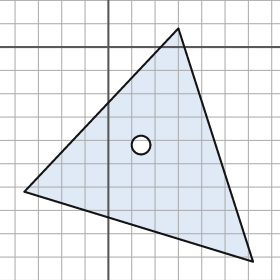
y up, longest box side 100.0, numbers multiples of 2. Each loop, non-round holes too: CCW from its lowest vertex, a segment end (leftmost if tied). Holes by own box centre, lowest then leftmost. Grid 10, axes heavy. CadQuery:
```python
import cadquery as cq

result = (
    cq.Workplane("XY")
    .moveTo(62.0, -92.0)
    .lineTo(30.0, 8.0)
    .lineTo(-36.0, -62.0)
    .close()
    .moveTo(14.0, -42.0)
    .circle(4.0)
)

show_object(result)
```